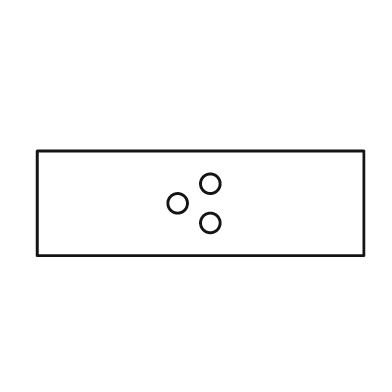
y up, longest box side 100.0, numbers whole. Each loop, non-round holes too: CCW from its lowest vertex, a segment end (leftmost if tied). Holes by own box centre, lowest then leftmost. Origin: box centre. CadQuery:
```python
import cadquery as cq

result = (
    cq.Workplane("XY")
    .moveTo(-50.0, -16.0)
    .lineTo(50.0, -16.0)
    .lineTo(50.0, 16.0)
    .lineTo(-50.0, 16.0)
    .close()
    .moveTo(3.0, -6.0)
    .circle(3.0)
    .moveTo(-7.0, 0.0)
    .circle(3.0)
    .moveTo(3.0, 6.0)
    .circle(3.0)
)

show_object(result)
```